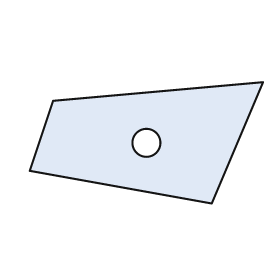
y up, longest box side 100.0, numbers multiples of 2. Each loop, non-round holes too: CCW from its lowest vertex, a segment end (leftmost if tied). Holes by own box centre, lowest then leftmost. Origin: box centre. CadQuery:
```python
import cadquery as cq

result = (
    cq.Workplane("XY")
    .moveTo(28.0, -26.0)
    .lineTo(50.0, 26.0)
    .lineTo(-40.0, 18.0)
    .lineTo(-50.0, -12.0)
    .close()
    .moveTo(0.0, 0.0)
    .circle(6.0)
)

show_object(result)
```